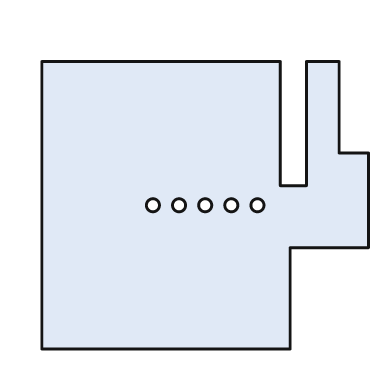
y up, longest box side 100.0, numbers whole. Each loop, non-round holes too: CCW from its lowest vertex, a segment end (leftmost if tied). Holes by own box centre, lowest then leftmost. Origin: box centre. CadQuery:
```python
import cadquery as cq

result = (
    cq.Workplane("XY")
    .moveTo(-50.0, -44.0)
    .lineTo(26.0, -44.0)
    .lineTo(26.0, -13.0)
    .lineTo(50.0, -13.0)
    .lineTo(50.0, 16.0)
    .lineTo(41.0, 16.0)
    .lineTo(41.0, 44.0)
    .lineTo(31.0, 44.0)
    .lineTo(31.0, 6.0)
    .lineTo(23.0, 6.0)
    .lineTo(23.0, 44.0)
    .lineTo(-50.0, 44.0)
    .close()
    .moveTo(-16.0, 0.0)
    .circle(2.0)
    .moveTo(-8.0, 0.0)
    .circle(2.0)
    .moveTo(0.0, 0.0)
    .circle(2.0)
    .moveTo(8.0, 0.0)
    .circle(2.0)
    .moveTo(16.0, 0.0)
    .circle(2.0)
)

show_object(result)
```